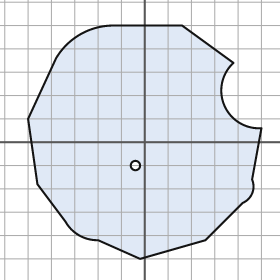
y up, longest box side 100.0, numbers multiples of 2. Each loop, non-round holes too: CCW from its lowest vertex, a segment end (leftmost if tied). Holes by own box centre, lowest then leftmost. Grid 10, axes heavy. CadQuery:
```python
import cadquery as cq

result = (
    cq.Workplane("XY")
    .moveTo(-2.0, -50.0)
    .lineTo(26.0, -42.0)
    .lineTo(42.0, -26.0)
    .threePointArc((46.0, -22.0), (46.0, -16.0))
    .lineTo(50.0, 6.0)
    .threePointArc((34.0, 16.0), (38.0, 34.0))
    .lineTo(16.0, 50.0)
    .lineTo(-14.0, 50.0)
    .threePointArc((-28.0, 46.0), (-38.0, 36.0))
    .lineTo(-50.0, 10.0)
    .lineTo(-46.0, -18.0)
    .lineTo(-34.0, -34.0)
    .threePointArc((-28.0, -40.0), (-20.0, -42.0))
    .close()
    .moveTo(-4.0, -10.0)
    .circle(2.0)
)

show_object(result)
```